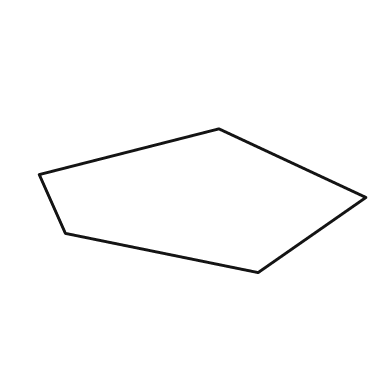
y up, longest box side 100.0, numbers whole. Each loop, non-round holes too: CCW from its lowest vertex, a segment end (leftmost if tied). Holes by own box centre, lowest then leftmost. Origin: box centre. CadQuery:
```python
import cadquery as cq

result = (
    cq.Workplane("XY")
    .moveTo(17.0, -22.0)
    .lineTo(50.0, 1.0)
    .lineTo(5.0, 22.0)
    .lineTo(-50.0, 8.0)
    .lineTo(-42.0, -10.0)
    .close()
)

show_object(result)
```